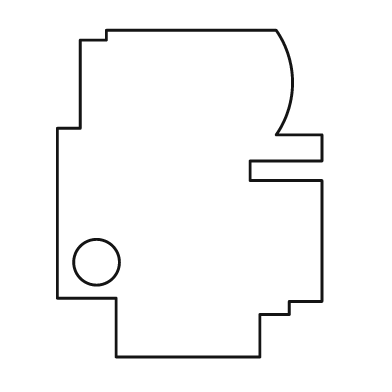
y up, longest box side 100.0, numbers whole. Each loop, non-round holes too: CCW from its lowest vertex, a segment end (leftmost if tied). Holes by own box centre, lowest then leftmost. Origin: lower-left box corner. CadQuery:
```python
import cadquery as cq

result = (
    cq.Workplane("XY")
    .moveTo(18.0, 0.0)
    .lineTo(62.0, 0.0)
    .lineTo(62.0, 13.0)
    .lineTo(71.0, 13.0)
    .lineTo(71.0, 17.0)
    .lineTo(81.0, 17.0)
    .lineTo(81.0, 54.0)
    .lineTo(59.0, 54.0)
    .lineTo(59.0, 60.0)
    .lineTo(81.0, 60.0)
    .lineTo(81.0, 68.0)
    .lineTo(67.0, 68.0)
    .threePointArc((72.0, 84.0), (67.0, 100.0))
    .lineTo(15.0, 100.0)
    .lineTo(15.0, 97.0)
    .lineTo(7.0, 97.0)
    .lineTo(7.0, 70.0)
    .lineTo(0.0, 70.0)
    .lineTo(0.0, 18.0)
    .lineTo(18.0, 18.0)
    .close()
    .moveTo(12.0, 29.0)
    .circle(7.0)
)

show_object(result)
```